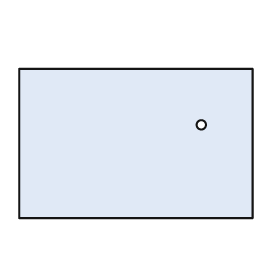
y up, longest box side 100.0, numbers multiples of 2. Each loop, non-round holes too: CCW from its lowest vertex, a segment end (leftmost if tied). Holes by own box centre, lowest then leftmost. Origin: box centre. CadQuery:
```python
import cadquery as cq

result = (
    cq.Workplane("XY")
    .moveTo(-50.0, -32.0)
    .lineTo(50.0, -32.0)
    .lineTo(50.0, 32.0)
    .lineTo(-50.0, 32.0)
    .close()
    .moveTo(28.0, 8.0)
    .circle(2.0)
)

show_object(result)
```